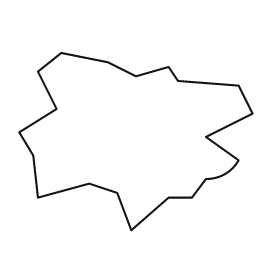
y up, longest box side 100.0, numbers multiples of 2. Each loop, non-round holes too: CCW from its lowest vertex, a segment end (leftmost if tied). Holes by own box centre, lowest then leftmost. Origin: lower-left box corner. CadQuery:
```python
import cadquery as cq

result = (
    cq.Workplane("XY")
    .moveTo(48.0, 0.0)
    .lineTo(64.0, 14.0)
    .lineTo(74.0, 14.0)
    .lineTo(80.0, 22.0)
    .threePointArc((88.0, 24.0), (94.0, 30.0))
    .lineTo(80.0, 40.0)
    .lineTo(100.0, 50.0)
    .lineTo(94.0, 62.0)
    .lineTo(68.0, 64.0)
    .lineTo(64.0, 70.0)
    .lineTo(50.0, 66.0)
    .lineTo(38.0, 72.0)
    .lineTo(18.0, 76.0)
    .lineTo(8.0, 68.0)
    .lineTo(16.0, 52.0)
    .lineTo(0.0, 42.0)
    .lineTo(6.0, 32.0)
    .lineTo(8.0, 14.0)
    .lineTo(30.0, 20.0)
    .lineTo(42.0, 16.0)
    .close()
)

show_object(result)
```